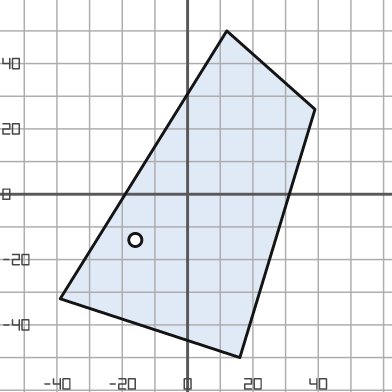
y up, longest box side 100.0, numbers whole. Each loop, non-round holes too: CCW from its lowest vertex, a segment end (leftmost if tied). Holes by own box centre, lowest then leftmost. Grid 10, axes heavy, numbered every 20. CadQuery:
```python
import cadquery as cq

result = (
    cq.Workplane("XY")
    .moveTo(16.0, -50.0)
    .lineTo(39.0, 26.0)
    .lineTo(12.0, 50.0)
    .lineTo(-39.0, -32.0)
    .close()
    .moveTo(-16.0, -14.0)
    .circle(2.0)
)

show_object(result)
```